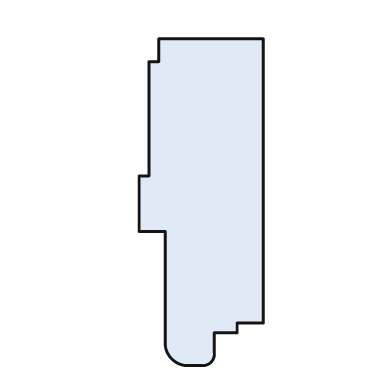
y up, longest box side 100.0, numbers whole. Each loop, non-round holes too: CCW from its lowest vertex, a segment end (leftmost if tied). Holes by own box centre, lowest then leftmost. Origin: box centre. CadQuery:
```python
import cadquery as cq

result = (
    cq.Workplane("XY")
    .moveTo(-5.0, -50.0)
    .lineTo(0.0, -50.0)
    .threePointArc((3.0, -49.0), (4.0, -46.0))
    .lineTo(4.0, -40.0)
    .lineTo(11.0, -40.0)
    .lineTo(11.0, -37.0)
    .lineTo(19.0, -37.0)
    .lineTo(19.0, 50.0)
    .lineTo(-13.0, 50.0)
    .lineTo(-13.0, 43.0)
    .lineTo(-16.0, 43.0)
    .lineTo(-16.0, 8.0)
    .lineTo(-19.0, 8.0)
    .lineTo(-19.0, -9.0)
    .lineTo(-11.0, -9.0)
    .lineTo(-11.0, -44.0)
    .threePointArc((-9.0, -48.0), (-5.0, -50.0))
    .close()
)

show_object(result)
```